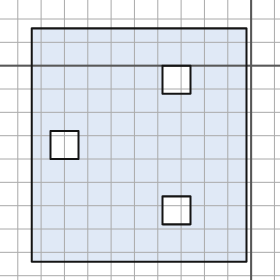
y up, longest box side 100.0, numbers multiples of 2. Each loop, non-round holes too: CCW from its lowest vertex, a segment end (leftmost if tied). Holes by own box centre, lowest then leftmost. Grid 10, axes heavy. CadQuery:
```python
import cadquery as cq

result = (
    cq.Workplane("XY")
    .moveTo(-94.0, -84.0)
    .lineTo(-2.0, -84.0)
    .lineTo(-2.0, 16.0)
    .lineTo(-94.0, 16.0)
    .close()
    .moveTo(-38.0, -68.0)
    .lineTo(-26.0, -68.0)
    .lineTo(-26.0, -56.0)
    .lineTo(-38.0, -56.0)
    .close()
    .moveTo(-86.0, -40.0)
    .lineTo(-74.0, -40.0)
    .lineTo(-74.0, -28.0)
    .lineTo(-86.0, -28.0)
    .close()
    .moveTo(-38.0, -12.0)
    .lineTo(-26.0, -12.0)
    .lineTo(-26.0, 0.0)
    .lineTo(-38.0, 0.0)
    .close()
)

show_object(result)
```